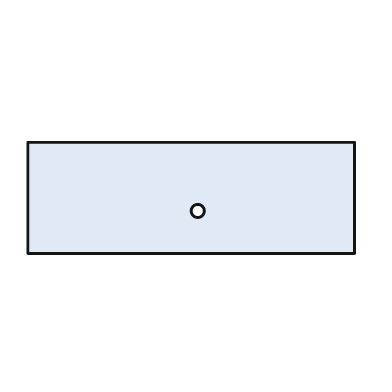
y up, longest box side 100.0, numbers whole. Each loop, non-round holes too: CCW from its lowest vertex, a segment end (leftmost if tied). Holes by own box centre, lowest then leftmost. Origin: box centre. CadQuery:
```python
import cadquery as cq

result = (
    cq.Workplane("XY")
    .moveTo(-50.0, -17.0)
    .lineTo(50.0, -17.0)
    .lineTo(50.0, 17.0)
    .lineTo(-50.0, 17.0)
    .close()
    .moveTo(2.0, -4.0)
    .circle(2.0)
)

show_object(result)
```